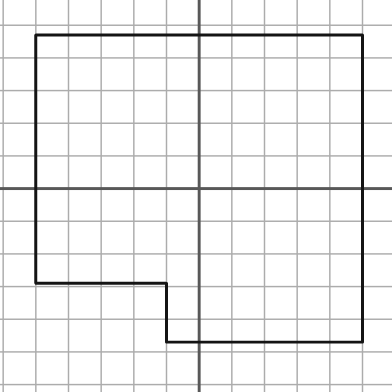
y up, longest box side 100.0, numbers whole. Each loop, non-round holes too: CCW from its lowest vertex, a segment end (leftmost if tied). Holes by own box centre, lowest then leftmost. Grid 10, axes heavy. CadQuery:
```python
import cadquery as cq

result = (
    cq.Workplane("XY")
    .moveTo(-10.0, -47.0)
    .lineTo(50.0, -47.0)
    .lineTo(50.0, 47.0)
    .lineTo(-50.0, 47.0)
    .lineTo(-50.0, -29.0)
    .lineTo(-10.0, -29.0)
    .close()
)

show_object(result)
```